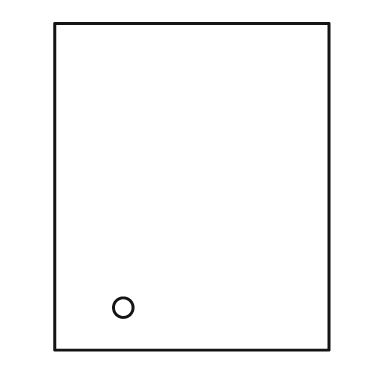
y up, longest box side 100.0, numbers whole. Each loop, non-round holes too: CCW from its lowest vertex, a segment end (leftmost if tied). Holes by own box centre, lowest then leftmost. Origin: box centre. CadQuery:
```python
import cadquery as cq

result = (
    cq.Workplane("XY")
    .moveTo(-42.0, -50.0)
    .lineTo(42.0, -50.0)
    .lineTo(42.0, 50.0)
    .lineTo(-42.0, 50.0)
    .close()
    .moveTo(-21.0, -37.0)
    .circle(3.0)
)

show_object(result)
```